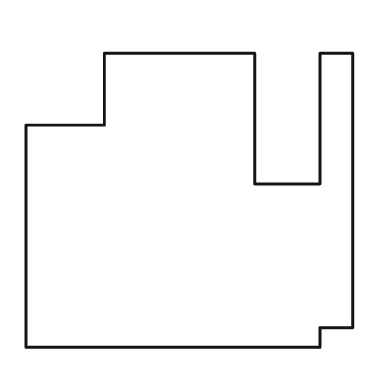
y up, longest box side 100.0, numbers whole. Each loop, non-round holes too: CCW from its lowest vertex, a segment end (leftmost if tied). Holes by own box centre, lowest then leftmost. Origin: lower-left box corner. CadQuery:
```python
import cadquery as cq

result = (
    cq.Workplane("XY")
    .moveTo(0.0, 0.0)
    .lineTo(90.0, 0.0)
    .lineTo(90.0, 6.0)
    .lineTo(100.0, 6.0)
    .lineTo(100.0, 90.0)
    .lineTo(90.0, 90.0)
    .lineTo(90.0, 50.0)
    .lineTo(70.0, 50.0)
    .lineTo(70.0, 90.0)
    .lineTo(24.0, 90.0)
    .lineTo(24.0, 68.0)
    .lineTo(0.0, 68.0)
    .close()
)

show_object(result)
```